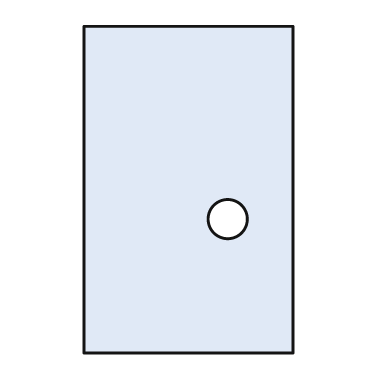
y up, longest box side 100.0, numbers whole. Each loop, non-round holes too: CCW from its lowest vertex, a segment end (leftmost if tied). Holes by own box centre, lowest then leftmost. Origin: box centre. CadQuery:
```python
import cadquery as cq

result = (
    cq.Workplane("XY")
    .moveTo(-32.0, -50.0)
    .lineTo(32.0, -50.0)
    .lineTo(32.0, 50.0)
    .lineTo(-32.0, 50.0)
    .close()
    .moveTo(12.0, -9.0)
    .circle(6.0)
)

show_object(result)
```